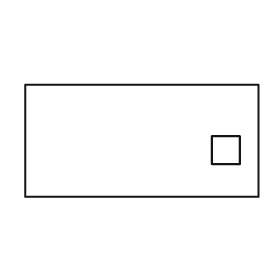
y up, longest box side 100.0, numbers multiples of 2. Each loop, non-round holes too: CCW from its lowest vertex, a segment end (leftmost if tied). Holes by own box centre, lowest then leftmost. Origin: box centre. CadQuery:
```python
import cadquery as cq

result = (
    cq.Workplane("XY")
    .moveTo(-50.0, -24.0)
    .lineTo(50.0, -24.0)
    .lineTo(50.0, 24.0)
    .lineTo(-50.0, 24.0)
    .close()
    .moveTo(30.0, -10.0)
    .lineTo(42.0, -10.0)
    .lineTo(42.0, 2.0)
    .lineTo(30.0, 2.0)
    .close()
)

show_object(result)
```